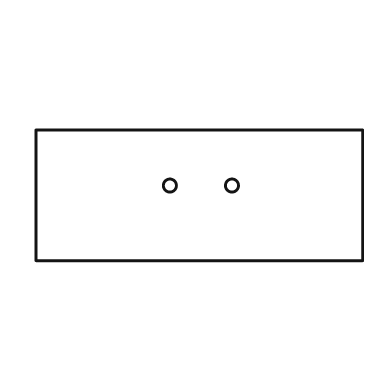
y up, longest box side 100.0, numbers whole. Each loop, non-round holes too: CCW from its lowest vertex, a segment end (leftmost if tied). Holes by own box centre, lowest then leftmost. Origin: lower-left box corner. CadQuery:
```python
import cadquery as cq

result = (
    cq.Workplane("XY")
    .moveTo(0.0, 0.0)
    .lineTo(100.0, 0.0)
    .lineTo(100.0, 40.0)
    .lineTo(0.0, 40.0)
    .close()
    .moveTo(41.0, 23.0)
    .circle(2.0)
    .moveTo(60.0, 23.0)
    .circle(2.0)
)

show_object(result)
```